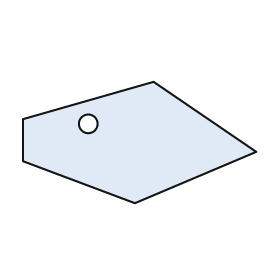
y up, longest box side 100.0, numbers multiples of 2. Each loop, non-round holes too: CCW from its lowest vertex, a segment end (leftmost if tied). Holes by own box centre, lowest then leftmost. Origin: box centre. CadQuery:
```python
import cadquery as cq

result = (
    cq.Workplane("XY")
    .moveTo(-2.0, -26.0)
    .lineTo(50.0, -4.0)
    .lineTo(6.0, 26.0)
    .lineTo(-50.0, 10.0)
    .lineTo(-50.0, -8.0)
    .close()
    .moveTo(-22.0, 8.0)
    .circle(4.0)
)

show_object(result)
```